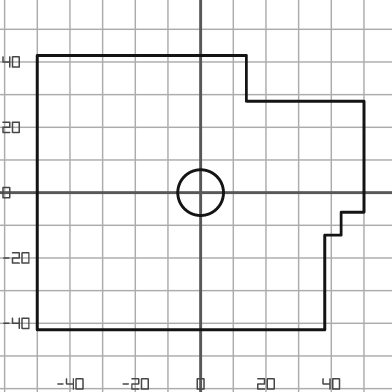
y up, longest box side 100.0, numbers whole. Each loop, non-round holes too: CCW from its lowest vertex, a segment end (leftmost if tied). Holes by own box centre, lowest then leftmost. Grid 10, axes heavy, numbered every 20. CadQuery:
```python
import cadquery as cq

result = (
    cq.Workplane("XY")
    .moveTo(-50.0, -42.0)
    .lineTo(38.0, -42.0)
    .lineTo(38.0, -13.0)
    .lineTo(43.0, -13.0)
    .lineTo(43.0, -6.0)
    .lineTo(50.0, -6.0)
    .lineTo(50.0, 28.0)
    .lineTo(14.0, 28.0)
    .lineTo(14.0, 42.0)
    .lineTo(-50.0, 42.0)
    .close()
    .moveTo(0.0, 0.0)
    .circle(7.0)
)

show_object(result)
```